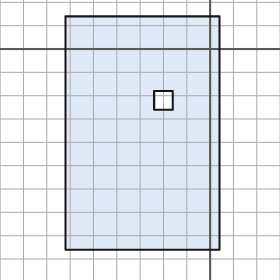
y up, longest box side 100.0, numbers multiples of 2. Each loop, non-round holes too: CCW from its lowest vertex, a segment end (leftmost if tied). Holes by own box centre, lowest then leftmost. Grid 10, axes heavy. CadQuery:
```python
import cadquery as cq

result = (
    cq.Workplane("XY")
    .moveTo(-62.0, -86.0)
    .lineTo(4.0, -86.0)
    .lineTo(4.0, 14.0)
    .lineTo(-62.0, 14.0)
    .close()
    .moveTo(-24.0, -26.0)
    .lineTo(-16.0, -26.0)
    .lineTo(-16.0, -18.0)
    .lineTo(-24.0, -18.0)
    .close()
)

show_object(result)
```